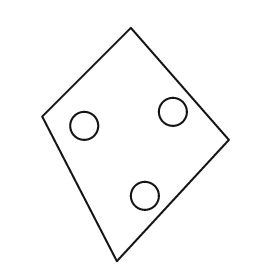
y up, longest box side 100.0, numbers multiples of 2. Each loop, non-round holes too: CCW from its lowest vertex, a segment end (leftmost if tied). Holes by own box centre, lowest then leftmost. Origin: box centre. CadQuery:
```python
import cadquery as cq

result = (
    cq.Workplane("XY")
    .moveTo(-8.0, -50.0)
    .lineTo(40.0, 2.0)
    .lineTo(-2.0, 50.0)
    .lineTo(-40.0, 12.0)
    .close()
    .moveTo(4.0, -22.0)
    .circle(6.0)
    .moveTo(-22.0, 8.0)
    .circle(6.0)
    .moveTo(16.0, 14.0)
    .circle(6.0)
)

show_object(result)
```